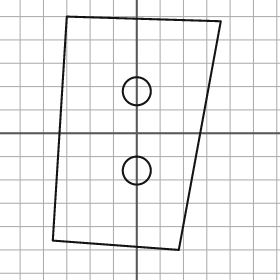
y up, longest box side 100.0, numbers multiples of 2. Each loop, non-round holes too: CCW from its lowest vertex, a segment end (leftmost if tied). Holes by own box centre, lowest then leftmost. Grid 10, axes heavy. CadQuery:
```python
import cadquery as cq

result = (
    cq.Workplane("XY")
    .moveTo(18.0, -50.0)
    .lineTo(36.0, 48.0)
    .lineTo(-30.0, 50.0)
    .lineTo(-36.0, -46.0)
    .close()
    .moveTo(0.0, -16.0)
    .circle(6.0)
    .moveTo(0.0, 18.0)
    .circle(6.0)
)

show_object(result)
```